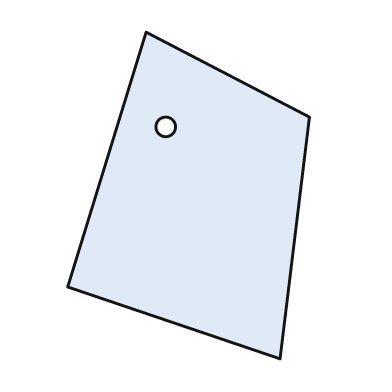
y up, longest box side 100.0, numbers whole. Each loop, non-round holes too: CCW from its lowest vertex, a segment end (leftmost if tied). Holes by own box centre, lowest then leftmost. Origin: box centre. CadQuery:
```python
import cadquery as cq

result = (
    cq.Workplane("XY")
    .moveTo(28.0, -50.0)
    .lineTo(37.0, 24.0)
    .lineTo(-13.0, 50.0)
    .lineTo(-37.0, -28.0)
    .close()
    .moveTo(-7.0, 21.0)
    .circle(3.0)
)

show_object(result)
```